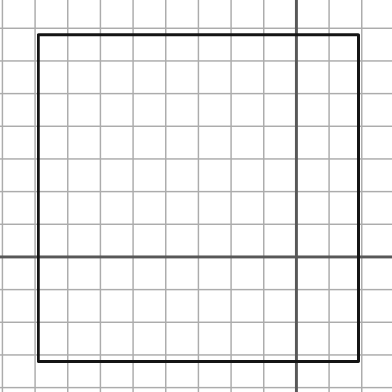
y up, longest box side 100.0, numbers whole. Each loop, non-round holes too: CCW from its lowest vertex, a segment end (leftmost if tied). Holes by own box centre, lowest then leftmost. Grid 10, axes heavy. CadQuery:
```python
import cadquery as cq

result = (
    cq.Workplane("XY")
    .moveTo(-79.0, -32.0)
    .lineTo(19.0, -32.0)
    .lineTo(19.0, 68.0)
    .lineTo(-79.0, 68.0)
    .close()
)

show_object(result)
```